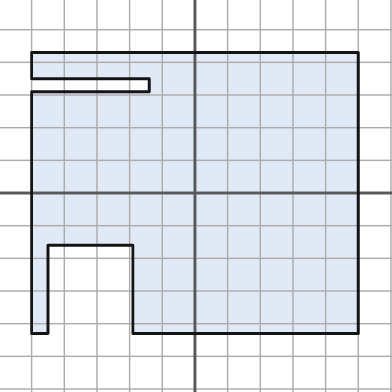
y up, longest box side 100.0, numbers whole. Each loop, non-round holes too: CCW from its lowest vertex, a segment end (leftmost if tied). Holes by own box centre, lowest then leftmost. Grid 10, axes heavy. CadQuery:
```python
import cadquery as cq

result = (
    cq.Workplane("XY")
    .moveTo(-50.0, -43.0)
    .lineTo(-45.0, -43.0)
    .lineTo(-45.0, -16.0)
    .lineTo(-19.0, -16.0)
    .lineTo(-19.0, -43.0)
    .lineTo(50.0, -43.0)
    .lineTo(50.0, 43.0)
    .lineTo(-50.0, 43.0)
    .lineTo(-50.0, 35.0)
    .lineTo(-14.0, 35.0)
    .lineTo(-14.0, 31.0)
    .lineTo(-50.0, 31.0)
    .close()
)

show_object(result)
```